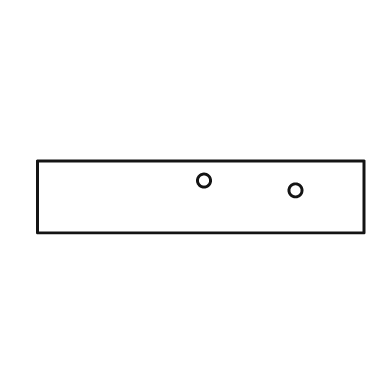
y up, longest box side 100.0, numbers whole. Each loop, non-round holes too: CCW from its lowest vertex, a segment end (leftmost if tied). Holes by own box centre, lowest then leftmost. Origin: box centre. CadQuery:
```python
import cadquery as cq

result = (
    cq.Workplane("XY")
    .moveTo(-50.0, -11.0)
    .lineTo(50.0, -11.0)
    .lineTo(50.0, 11.0)
    .lineTo(-50.0, 11.0)
    .close()
    .moveTo(29.0, 2.0)
    .circle(2.0)
    .moveTo(1.0, 5.0)
    .circle(2.0)
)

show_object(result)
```